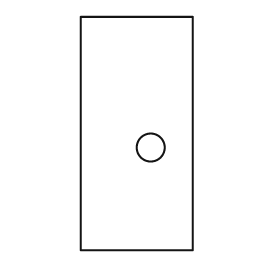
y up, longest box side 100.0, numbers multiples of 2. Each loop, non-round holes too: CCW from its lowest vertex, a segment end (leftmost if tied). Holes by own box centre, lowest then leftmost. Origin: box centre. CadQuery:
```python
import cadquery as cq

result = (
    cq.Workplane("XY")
    .moveTo(-24.0, -50.0)
    .lineTo(24.0, -50.0)
    .lineTo(24.0, 50.0)
    .lineTo(-24.0, 50.0)
    .close()
    .moveTo(6.0, -6.0)
    .circle(6.0)
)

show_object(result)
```